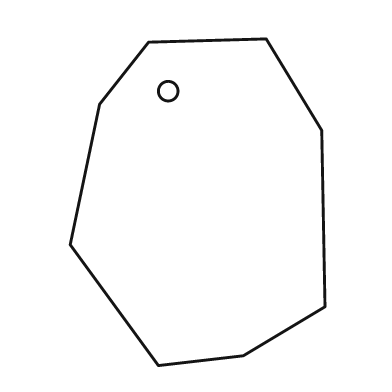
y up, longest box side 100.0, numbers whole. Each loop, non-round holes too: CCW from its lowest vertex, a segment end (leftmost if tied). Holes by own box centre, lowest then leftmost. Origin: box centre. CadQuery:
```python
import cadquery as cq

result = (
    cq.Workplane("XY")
    .moveTo(-12.0, -50.0)
    .lineTo(14.0, -47.0)
    .lineTo(39.0, -32.0)
    .lineTo(38.0, 22.0)
    .lineTo(21.0, 50.0)
    .lineTo(-15.0, 49.0)
    .lineTo(-30.0, 30.0)
    .lineTo(-39.0, -13.0)
    .close()
    .moveTo(-9.0, 34.0)
    .circle(3.0)
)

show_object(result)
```